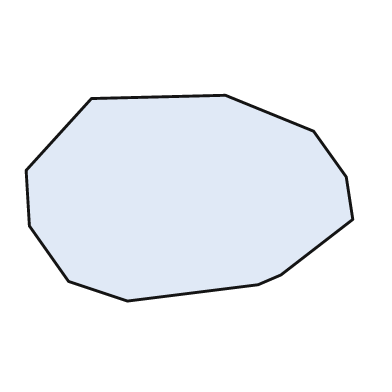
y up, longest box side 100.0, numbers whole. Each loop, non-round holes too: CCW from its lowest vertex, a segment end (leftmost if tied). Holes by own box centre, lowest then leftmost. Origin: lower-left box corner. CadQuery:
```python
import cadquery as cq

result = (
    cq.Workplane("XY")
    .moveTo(31.0, 0.0)
    .lineTo(71.0, 5.0)
    .lineTo(78.0, 8.0)
    .lineTo(100.0, 25.0)
    .lineTo(98.0, 38.0)
    .lineTo(88.0, 52.0)
    .lineTo(61.0, 63.0)
    .lineTo(20.0, 62.0)
    .lineTo(0.0, 40.0)
    .lineTo(1.0, 23.0)
    .lineTo(13.0, 6.0)
    .close()
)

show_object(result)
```